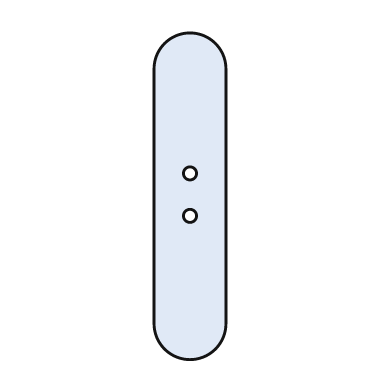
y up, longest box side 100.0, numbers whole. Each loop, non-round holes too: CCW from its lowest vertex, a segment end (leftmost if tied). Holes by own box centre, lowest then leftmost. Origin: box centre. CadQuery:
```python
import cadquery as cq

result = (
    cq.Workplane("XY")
    .moveTo(-11.0, -39.0)
    .threePointArc((0.0, -50.0), (11.0, -39.0))
    .lineTo(11.0, 39.0)
    .threePointArc((0.0, 50.0), (-11.0, 39.0))
    .close()
    .moveTo(0.0, -6.0)
    .circle(2.0)
    .moveTo(0.0, 7.0)
    .circle(2.0)
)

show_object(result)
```